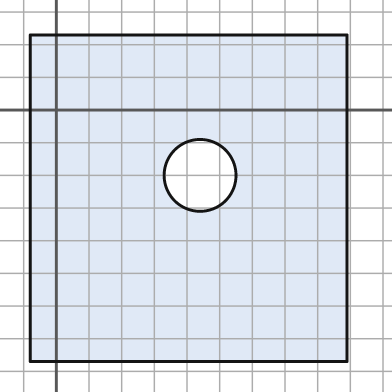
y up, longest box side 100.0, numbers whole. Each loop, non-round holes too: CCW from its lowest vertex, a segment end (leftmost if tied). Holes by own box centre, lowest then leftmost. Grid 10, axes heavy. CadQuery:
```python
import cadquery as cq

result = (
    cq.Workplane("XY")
    .moveTo(-8.0, -77.0)
    .lineTo(89.0, -77.0)
    .lineTo(89.0, 23.0)
    .lineTo(-8.0, 23.0)
    .close()
    .moveTo(44.0, -20.0)
    .circle(11.0)
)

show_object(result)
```